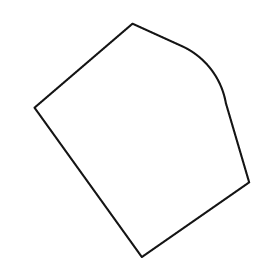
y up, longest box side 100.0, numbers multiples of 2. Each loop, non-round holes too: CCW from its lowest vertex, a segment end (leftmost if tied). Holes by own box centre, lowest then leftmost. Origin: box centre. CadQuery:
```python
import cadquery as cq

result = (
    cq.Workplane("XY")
    .moveTo(0.0, -50.0)
    .lineTo(46.0, -18.0)
    .lineTo(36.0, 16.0)
    .threePointArc((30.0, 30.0), (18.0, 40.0))
    .lineTo(-4.0, 50.0)
    .lineTo(-46.0, 14.0)
    .close()
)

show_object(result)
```